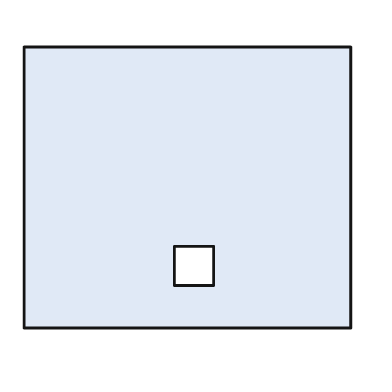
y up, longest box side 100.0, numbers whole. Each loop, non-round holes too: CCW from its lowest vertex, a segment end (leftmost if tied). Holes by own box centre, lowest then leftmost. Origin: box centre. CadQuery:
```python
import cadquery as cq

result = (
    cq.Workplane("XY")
    .moveTo(-50.0, -43.0)
    .lineTo(50.0, -43.0)
    .lineTo(50.0, 43.0)
    .lineTo(-50.0, 43.0)
    .close()
    .moveTo(-4.0, -30.0)
    .lineTo(8.0, -30.0)
    .lineTo(8.0, -18.0)
    .lineTo(-4.0, -18.0)
    .close()
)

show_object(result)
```